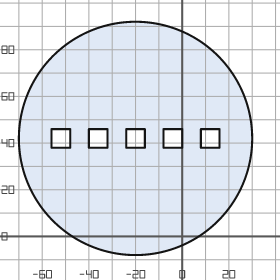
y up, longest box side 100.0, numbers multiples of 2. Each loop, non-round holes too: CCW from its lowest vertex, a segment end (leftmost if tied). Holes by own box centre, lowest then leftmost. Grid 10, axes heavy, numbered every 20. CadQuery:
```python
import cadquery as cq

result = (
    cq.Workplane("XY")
    .moveTo(-20.0, 42.0)
    .circle(50.0)
    .moveTo(-56.0, 38.0)
    .lineTo(-48.0, 38.0)
    .lineTo(-48.0, 46.0)
    .lineTo(-56.0, 46.0)
    .close()
    .moveTo(-40.0, 38.0)
    .lineTo(-32.0, 38.0)
    .lineTo(-32.0, 46.0)
    .lineTo(-40.0, 46.0)
    .close()
    .moveTo(-24.0, 38.0)
    .lineTo(-16.0, 38.0)
    .lineTo(-16.0, 46.0)
    .lineTo(-24.0, 46.0)
    .close()
    .moveTo(-8.0, 38.0)
    .lineTo(0.0, 38.0)
    .lineTo(0.0, 46.0)
    .lineTo(-8.0, 46.0)
    .close()
    .moveTo(8.0, 38.0)
    .lineTo(16.0, 38.0)
    .lineTo(16.0, 46.0)
    .lineTo(8.0, 46.0)
    .close()
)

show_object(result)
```